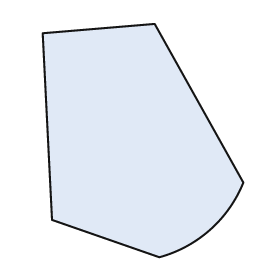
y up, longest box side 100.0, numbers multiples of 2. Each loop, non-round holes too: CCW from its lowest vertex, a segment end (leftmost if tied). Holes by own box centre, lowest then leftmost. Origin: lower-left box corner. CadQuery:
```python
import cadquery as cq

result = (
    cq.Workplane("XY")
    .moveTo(50.0, 0.0)
    .threePointArc((72.0, 12.0), (86.0, 32.0))
    .lineTo(48.0, 100.0)
    .lineTo(0.0, 96.0)
    .lineTo(4.0, 16.0)
    .close()
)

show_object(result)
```